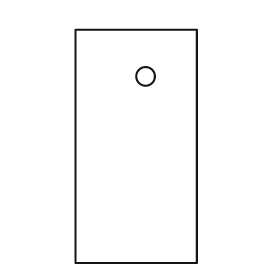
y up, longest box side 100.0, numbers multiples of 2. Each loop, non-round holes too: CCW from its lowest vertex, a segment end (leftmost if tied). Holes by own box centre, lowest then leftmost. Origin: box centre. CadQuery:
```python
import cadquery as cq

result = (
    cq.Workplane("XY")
    .moveTo(-26.0, -50.0)
    .lineTo(26.0, -50.0)
    .lineTo(26.0, 50.0)
    .lineTo(-26.0, 50.0)
    .close()
    .moveTo(4.0, 30.0)
    .circle(4.0)
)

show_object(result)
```